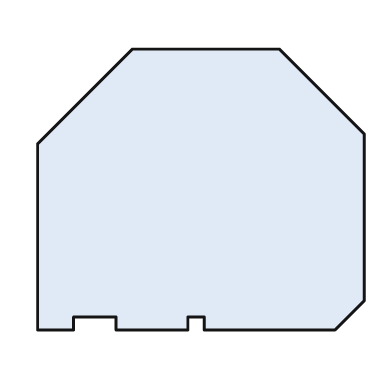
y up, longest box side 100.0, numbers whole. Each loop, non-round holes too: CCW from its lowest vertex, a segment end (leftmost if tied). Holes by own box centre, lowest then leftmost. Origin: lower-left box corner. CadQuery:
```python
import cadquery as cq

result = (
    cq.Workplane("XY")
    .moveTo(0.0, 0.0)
    .lineTo(11.0, 0.0)
    .lineTo(11.0, 4.0)
    .lineTo(24.0, 4.0)
    .lineTo(24.0, 0.0)
    .lineTo(46.0, 0.0)
    .lineTo(46.0, 4.0)
    .lineTo(51.0, 4.0)
    .lineTo(51.0, 0.0)
    .lineTo(91.0, 0.0)
    .lineTo(100.0, 9.0)
    .lineTo(100.0, 60.0)
    .lineTo(74.0, 86.0)
    .lineTo(29.0, 86.0)
    .lineTo(0.0, 57.0)
    .close()
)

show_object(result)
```